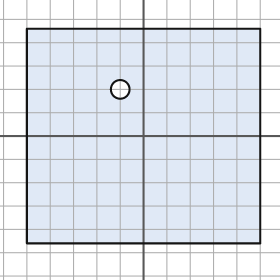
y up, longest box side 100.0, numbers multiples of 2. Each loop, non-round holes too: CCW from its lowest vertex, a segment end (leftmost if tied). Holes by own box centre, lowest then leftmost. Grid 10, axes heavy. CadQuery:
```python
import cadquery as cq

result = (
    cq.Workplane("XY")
    .moveTo(-50.0, -46.0)
    .lineTo(50.0, -46.0)
    .lineTo(50.0, 46.0)
    .lineTo(-50.0, 46.0)
    .close()
    .moveTo(-10.0, 20.0)
    .circle(4.0)
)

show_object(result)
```